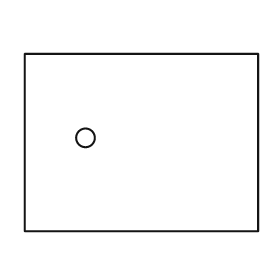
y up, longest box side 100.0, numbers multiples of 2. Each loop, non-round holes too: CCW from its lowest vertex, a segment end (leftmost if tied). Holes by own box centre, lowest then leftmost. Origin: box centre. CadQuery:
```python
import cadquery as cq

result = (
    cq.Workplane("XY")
    .moveTo(-50.0, -38.0)
    .lineTo(50.0, -38.0)
    .lineTo(50.0, 38.0)
    .lineTo(-50.0, 38.0)
    .close()
    .moveTo(-24.0, 2.0)
    .circle(4.0)
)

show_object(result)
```